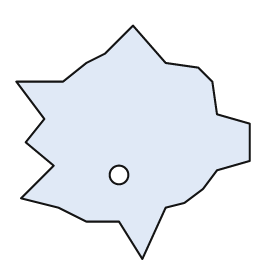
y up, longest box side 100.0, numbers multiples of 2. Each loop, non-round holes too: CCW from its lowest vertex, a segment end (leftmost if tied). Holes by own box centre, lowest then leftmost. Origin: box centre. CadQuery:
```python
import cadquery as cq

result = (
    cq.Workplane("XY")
    .moveTo(4.0, -50.0)
    .lineTo(14.0, -28.0)
    .lineTo(22.0, -26.0)
    .lineTo(30.0, -20.0)
    .lineTo(36.0, -12.0)
    .lineTo(50.0, -8.0)
    .lineTo(50.0, 8.0)
    .lineTo(36.0, 12.0)
    .lineTo(34.0, 26.0)
    .lineTo(28.0, 32.0)
    .lineTo(14.0, 34.0)
    .lineTo(0.0, 50.0)
    .lineTo(-12.0, 38.0)
    .lineTo(-20.0, 34.0)
    .lineTo(-30.0, 26.0)
    .lineTo(-50.0, 26.0)
    .lineTo(-38.0, 10.0)
    .lineTo(-46.0, 0.0)
    .lineTo(-34.0, -10.0)
    .lineTo(-48.0, -24.0)
    .lineTo(-32.0, -28.0)
    .lineTo(-20.0, -34.0)
    .lineTo(-6.0, -34.0)
    .close()
    .moveTo(-6.0, -14.0)
    .circle(4.0)
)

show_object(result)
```